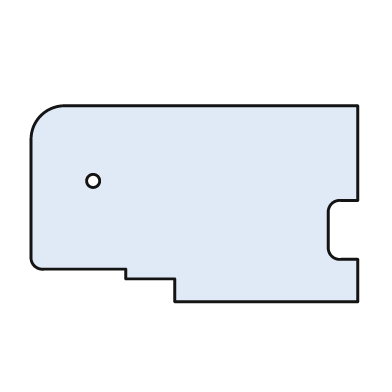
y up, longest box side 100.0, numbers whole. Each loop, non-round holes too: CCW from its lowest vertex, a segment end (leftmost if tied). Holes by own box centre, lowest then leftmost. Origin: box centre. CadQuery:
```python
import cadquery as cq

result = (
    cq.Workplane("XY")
    .moveTo(-6.0, -30.0)
    .lineTo(50.0, -30.0)
    .lineTo(50.0, -17.0)
    .lineTo(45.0, -17.0)
    .threePointArc((42.0, -16.0), (41.0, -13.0))
    .lineTo(41.0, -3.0)
    .threePointArc((42.0, 0.0), (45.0, 1.0))
    .lineTo(50.0, 1.0)
    .lineTo(50.0, 30.0)
    .lineTo(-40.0, 30.0)
    .threePointArc((-47.0, 27.0), (-50.0, 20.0))
    .lineTo(-50.0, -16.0)
    .threePointArc((-49.0, -19.0), (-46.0, -20.0))
    .lineTo(-21.0, -20.0)
    .lineTo(-21.0, -23.0)
    .lineTo(-6.0, -23.0)
    .close()
    .moveTo(-31.0, 7.0)
    .circle(2.0)
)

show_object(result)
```